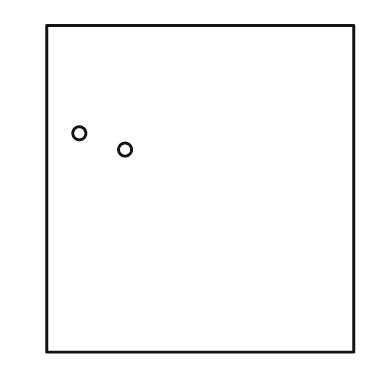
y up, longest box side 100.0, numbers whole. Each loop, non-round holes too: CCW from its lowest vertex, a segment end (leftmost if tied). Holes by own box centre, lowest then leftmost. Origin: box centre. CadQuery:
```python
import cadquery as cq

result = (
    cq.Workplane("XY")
    .moveTo(-47.0, -50.0)
    .lineTo(47.0, -50.0)
    .lineTo(47.0, 50.0)
    .lineTo(-47.0, 50.0)
    .close()
    .moveTo(-23.0, 12.0)
    .circle(2.0)
    .moveTo(-37.0, 17.0)
    .circle(2.0)
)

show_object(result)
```